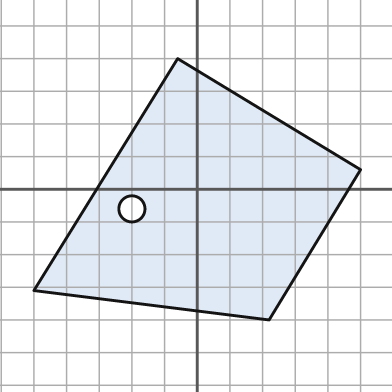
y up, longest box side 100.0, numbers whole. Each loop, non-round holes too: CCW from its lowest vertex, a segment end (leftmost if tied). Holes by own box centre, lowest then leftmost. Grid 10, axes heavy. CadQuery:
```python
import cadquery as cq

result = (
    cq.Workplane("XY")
    .moveTo(22.0, -40.0)
    .lineTo(50.0, 6.0)
    .lineTo(-6.0, 40.0)
    .lineTo(-50.0, -31.0)
    .close()
    .moveTo(-20.0, -6.0)
    .circle(4.0)
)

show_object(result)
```